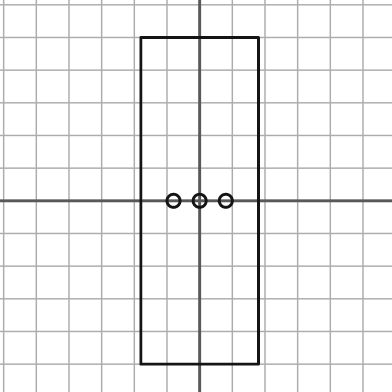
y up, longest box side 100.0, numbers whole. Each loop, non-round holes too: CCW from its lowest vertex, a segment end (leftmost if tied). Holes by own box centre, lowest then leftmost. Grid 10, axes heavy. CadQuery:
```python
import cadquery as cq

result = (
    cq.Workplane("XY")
    .moveTo(-18.0, -50.0)
    .lineTo(18.0, -50.0)
    .lineTo(18.0, 50.0)
    .lineTo(-18.0, 50.0)
    .close()
    .moveTo(-8.0, 0.0)
    .circle(2.0)
    .moveTo(0.0, 0.0)
    .circle(2.0)
    .moveTo(8.0, 0.0)
    .circle(2.0)
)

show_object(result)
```